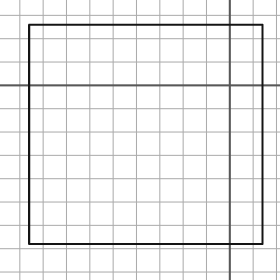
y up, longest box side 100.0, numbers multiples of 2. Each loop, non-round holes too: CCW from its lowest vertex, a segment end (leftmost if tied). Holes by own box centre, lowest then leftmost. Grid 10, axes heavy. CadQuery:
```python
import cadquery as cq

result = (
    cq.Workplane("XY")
    .moveTo(-86.0, -68.0)
    .lineTo(14.0, -68.0)
    .lineTo(14.0, 26.0)
    .lineTo(-86.0, 26.0)
    .close()
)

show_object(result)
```